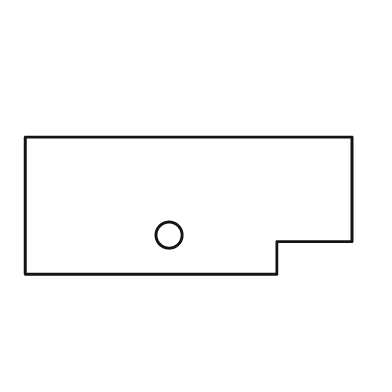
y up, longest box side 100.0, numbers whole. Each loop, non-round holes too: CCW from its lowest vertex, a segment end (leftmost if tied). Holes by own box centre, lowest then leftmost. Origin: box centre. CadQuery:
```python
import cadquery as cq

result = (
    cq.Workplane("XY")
    .moveTo(-50.0, -21.0)
    .lineTo(27.0, -21.0)
    .lineTo(27.0, -11.0)
    .lineTo(50.0, -11.0)
    .lineTo(50.0, 21.0)
    .lineTo(-50.0, 21.0)
    .close()
    .moveTo(-6.0, -9.0)
    .circle(4.0)
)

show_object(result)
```